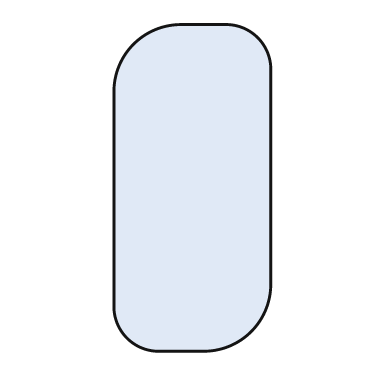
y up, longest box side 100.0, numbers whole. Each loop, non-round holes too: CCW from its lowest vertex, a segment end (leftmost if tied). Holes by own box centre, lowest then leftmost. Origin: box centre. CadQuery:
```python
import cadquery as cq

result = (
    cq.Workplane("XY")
    .moveTo(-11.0, -50.0)
    .lineTo(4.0, -50.0)
    .threePointArc((18.0, -44.0), (24.0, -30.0))
    .lineTo(24.0, 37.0)
    .threePointArc((20.0, 46.0), (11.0, 50.0))
    .lineTo(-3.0, 50.0)
    .threePointArc((-18.0, 44.0), (-24.0, 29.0))
    .lineTo(-24.0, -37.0)
    .threePointArc((-20.0, -46.0), (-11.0, -50.0))
    .close()
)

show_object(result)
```